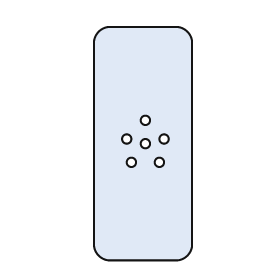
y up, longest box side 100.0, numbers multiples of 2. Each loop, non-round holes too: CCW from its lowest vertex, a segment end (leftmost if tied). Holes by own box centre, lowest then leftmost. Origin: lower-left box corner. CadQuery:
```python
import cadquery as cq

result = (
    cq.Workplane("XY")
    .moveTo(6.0, 0.0)
    .lineTo(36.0, 0.0)
    .threePointArc((40.0, 2.0), (42.0, 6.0))
    .lineTo(42.0, 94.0)
    .threePointArc((40.0, 98.0), (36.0, 100.0))
    .lineTo(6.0, 100.0)
    .threePointArc((2.0, 98.0), (0.0, 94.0))
    .lineTo(0.0, 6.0)
    .threePointArc((2.0, 2.0), (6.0, 0.0))
    .close()
    .moveTo(16.0, 42.0)
    .circle(2.0)
    .moveTo(28.0, 42.0)
    .circle(2.0)
    .moveTo(22.0, 50.0)
    .circle(2.0)
    .moveTo(14.0, 52.0)
    .circle(2.0)
    .moveTo(30.0, 52.0)
    .circle(2.0)
    .moveTo(22.0, 60.0)
    .circle(2.0)
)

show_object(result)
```